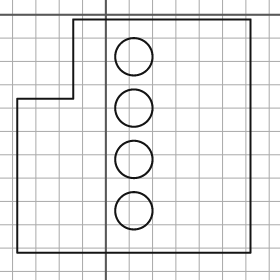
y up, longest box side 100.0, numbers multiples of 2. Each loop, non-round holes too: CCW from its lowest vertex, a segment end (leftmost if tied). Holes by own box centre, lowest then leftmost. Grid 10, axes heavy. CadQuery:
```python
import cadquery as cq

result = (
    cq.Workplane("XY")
    .moveTo(-38.0, -102.0)
    .lineTo(62.0, -102.0)
    .lineTo(62.0, -2.0)
    .lineTo(-14.0, -2.0)
    .lineTo(-14.0, -36.0)
    .lineTo(-38.0, -36.0)
    .close()
    .moveTo(12.0, -84.0)
    .circle(8.0)
    .moveTo(12.0, -62.0)
    .circle(8.0)
    .moveTo(12.0, -40.0)
    .circle(8.0)
    .moveTo(12.0, -18.0)
    .circle(8.0)
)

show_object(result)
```